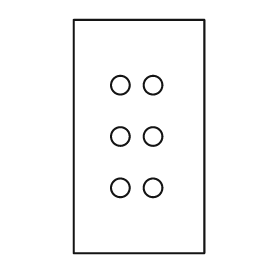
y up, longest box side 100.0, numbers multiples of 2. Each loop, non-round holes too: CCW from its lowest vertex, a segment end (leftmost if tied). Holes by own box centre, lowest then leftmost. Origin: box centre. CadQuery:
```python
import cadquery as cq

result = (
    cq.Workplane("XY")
    .moveTo(-28.0, -50.0)
    .lineTo(28.0, -50.0)
    .lineTo(28.0, 50.0)
    .lineTo(-28.0, 50.0)
    .close()
    .moveTo(-8.0, -22.0)
    .circle(4.0)
    .moveTo(6.0, -22.0)
    .circle(4.0)
    .moveTo(-8.0, 0.0)
    .circle(4.0)
    .moveTo(6.0, 0.0)
    .circle(4.0)
    .moveTo(-8.0, 22.0)
    .circle(4.0)
    .moveTo(6.0, 22.0)
    .circle(4.0)
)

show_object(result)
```